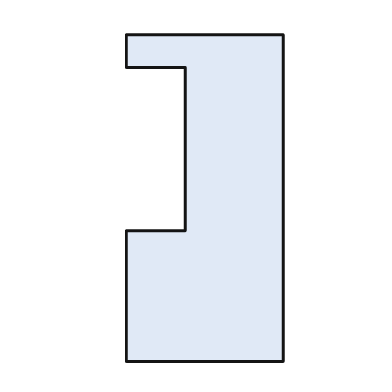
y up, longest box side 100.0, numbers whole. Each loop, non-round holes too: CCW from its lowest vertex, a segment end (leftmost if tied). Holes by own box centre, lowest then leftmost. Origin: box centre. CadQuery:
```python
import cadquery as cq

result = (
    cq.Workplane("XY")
    .moveTo(-24.0, -50.0)
    .lineTo(24.0, -50.0)
    .lineTo(24.0, 50.0)
    .lineTo(-24.0, 50.0)
    .lineTo(-24.0, 40.0)
    .lineTo(-6.0, 40.0)
    .lineTo(-6.0, -10.0)
    .lineTo(-24.0, -10.0)
    .close()
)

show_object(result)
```